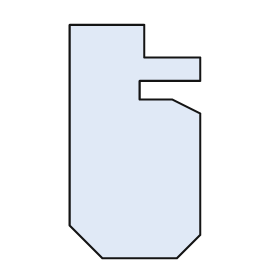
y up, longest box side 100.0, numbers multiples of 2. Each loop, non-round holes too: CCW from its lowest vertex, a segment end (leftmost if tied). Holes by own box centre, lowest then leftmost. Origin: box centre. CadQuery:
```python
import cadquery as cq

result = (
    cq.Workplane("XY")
    .moveTo(-14.0, -50.0)
    .lineTo(18.0, -50.0)
    .lineTo(28.0, -40.0)
    .lineTo(28.0, 12.0)
    .lineTo(16.0, 18.0)
    .lineTo(2.0, 18.0)
    .lineTo(2.0, 26.0)
    .lineTo(28.0, 26.0)
    .lineTo(28.0, 36.0)
    .lineTo(4.0, 36.0)
    .lineTo(4.0, 50.0)
    .lineTo(-28.0, 50.0)
    .lineTo(-28.0, -36.0)
    .close()
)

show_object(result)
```